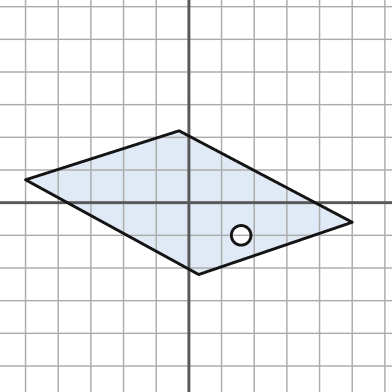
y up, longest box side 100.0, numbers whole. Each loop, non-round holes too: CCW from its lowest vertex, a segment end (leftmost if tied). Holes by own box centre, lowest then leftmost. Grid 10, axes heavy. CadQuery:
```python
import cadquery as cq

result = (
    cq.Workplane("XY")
    .moveTo(3.0, -22.0)
    .lineTo(50.0, -6.0)
    .lineTo(-3.0, 22.0)
    .lineTo(-50.0, 7.0)
    .close()
    .moveTo(16.0, -10.0)
    .circle(3.0)
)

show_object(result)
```